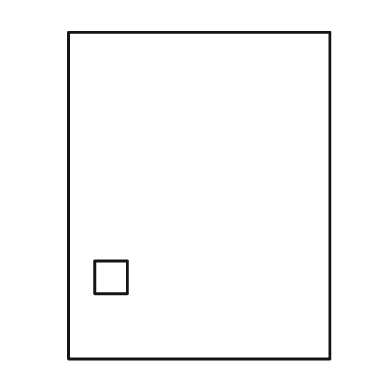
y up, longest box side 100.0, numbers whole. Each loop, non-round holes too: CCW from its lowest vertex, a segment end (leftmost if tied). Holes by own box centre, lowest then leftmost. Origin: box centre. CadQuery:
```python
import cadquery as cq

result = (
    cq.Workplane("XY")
    .moveTo(-40.0, -50.0)
    .lineTo(40.0, -50.0)
    .lineTo(40.0, 50.0)
    .lineTo(-40.0, 50.0)
    .close()
    .moveTo(-32.0, -30.0)
    .lineTo(-22.0, -30.0)
    .lineTo(-22.0, -20.0)
    .lineTo(-32.0, -20.0)
    .close()
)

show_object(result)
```